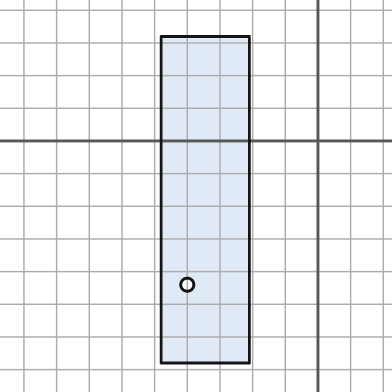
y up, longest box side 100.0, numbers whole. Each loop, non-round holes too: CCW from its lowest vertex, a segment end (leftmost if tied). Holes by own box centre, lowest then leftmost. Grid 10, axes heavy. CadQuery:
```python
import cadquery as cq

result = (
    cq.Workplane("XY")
    .moveTo(-48.0, -68.0)
    .lineTo(-21.0, -68.0)
    .lineTo(-21.0, 32.0)
    .lineTo(-48.0, 32.0)
    .close()
    .moveTo(-40.0, -44.0)
    .circle(2.0)
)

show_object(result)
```